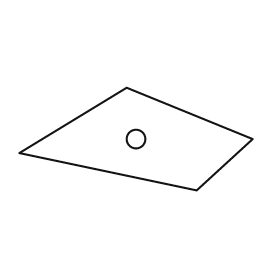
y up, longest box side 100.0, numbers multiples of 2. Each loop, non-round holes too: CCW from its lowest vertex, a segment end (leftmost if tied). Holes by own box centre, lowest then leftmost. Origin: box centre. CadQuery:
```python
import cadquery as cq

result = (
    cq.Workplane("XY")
    .moveTo(26.0, -22.0)
    .lineTo(50.0, 0.0)
    .lineTo(-4.0, 22.0)
    .lineTo(-50.0, -6.0)
    .close()
    .moveTo(0.0, 0.0)
    .circle(4.0)
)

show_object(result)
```